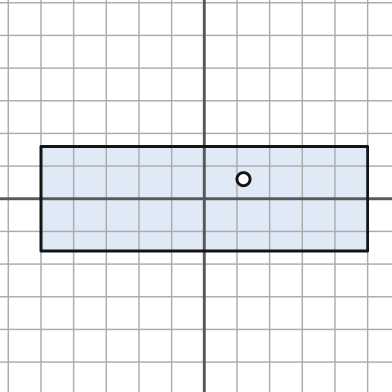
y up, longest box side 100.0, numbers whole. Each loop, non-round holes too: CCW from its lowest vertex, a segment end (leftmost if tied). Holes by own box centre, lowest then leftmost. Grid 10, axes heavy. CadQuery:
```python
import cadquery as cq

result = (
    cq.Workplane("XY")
    .moveTo(-50.0, -16.0)
    .lineTo(50.0, -16.0)
    .lineTo(50.0, 16.0)
    .lineTo(-50.0, 16.0)
    .close()
    .moveTo(12.0, 6.0)
    .circle(2.0)
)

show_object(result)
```